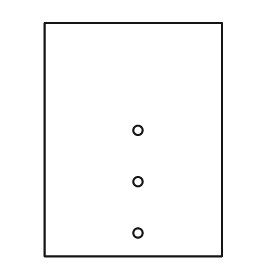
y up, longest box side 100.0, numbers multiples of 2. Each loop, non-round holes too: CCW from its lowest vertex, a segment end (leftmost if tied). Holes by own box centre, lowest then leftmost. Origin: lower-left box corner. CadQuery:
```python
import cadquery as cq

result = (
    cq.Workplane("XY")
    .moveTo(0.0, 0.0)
    .lineTo(76.0, 0.0)
    .lineTo(76.0, 100.0)
    .lineTo(0.0, 100.0)
    .close()
    .moveTo(40.0, 10.0)
    .circle(2.0)
    .moveTo(40.0, 32.0)
    .circle(2.0)
    .moveTo(40.0, 54.0)
    .circle(2.0)
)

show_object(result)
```